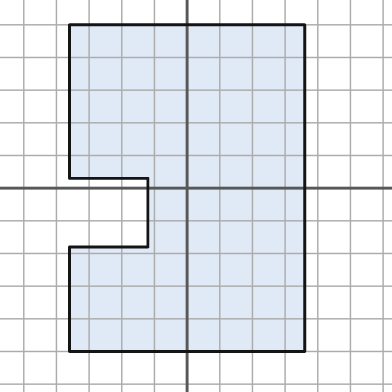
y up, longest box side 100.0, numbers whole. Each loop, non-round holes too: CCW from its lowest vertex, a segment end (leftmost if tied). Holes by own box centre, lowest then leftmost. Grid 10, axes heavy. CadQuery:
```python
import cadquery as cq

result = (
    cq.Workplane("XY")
    .moveTo(-36.0, -50.0)
    .lineTo(36.0, -50.0)
    .lineTo(36.0, 50.0)
    .lineTo(-36.0, 50.0)
    .lineTo(-36.0, 3.0)
    .lineTo(-12.0, 3.0)
    .lineTo(-12.0, -18.0)
    .lineTo(-36.0, -18.0)
    .close()
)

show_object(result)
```